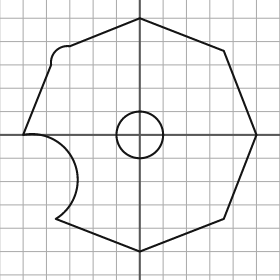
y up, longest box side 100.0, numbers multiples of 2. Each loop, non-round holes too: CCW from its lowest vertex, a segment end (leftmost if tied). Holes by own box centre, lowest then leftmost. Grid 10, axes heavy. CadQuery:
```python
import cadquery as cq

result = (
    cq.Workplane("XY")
    .moveTo(0.0, -50.0)
    .lineTo(36.0, -36.0)
    .lineTo(50.0, 0.0)
    .lineTo(36.0, 36.0)
    .lineTo(0.0, 50.0)
    .lineTo(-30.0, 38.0)
    .threePointArc((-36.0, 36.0), (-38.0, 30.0))
    .lineTo(-50.0, 0.0)
    .threePointArc((-28.0, -12.0), (-36.0, -36.0))
    .close()
    .moveTo(0.0, 0.0)
    .circle(10.0)
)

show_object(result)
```